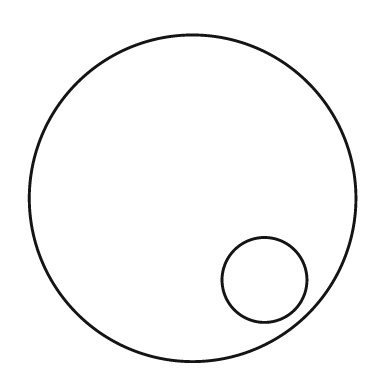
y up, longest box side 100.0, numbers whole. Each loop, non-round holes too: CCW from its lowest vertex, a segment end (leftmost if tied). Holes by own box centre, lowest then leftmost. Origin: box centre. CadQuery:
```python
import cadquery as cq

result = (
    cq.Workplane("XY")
    .moveTo(0.0, 0.0)
    .circle(50.0)
    .moveTo(22.0, -25.0)
    .circle(13.0)
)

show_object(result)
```